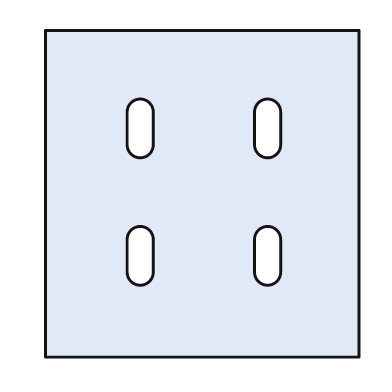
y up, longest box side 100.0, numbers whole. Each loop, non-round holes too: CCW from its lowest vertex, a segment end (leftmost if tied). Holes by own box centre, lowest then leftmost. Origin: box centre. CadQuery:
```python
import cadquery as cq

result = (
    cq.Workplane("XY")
    .moveTo(-48.0, -50.0)
    .lineTo(48.0, -50.0)
    .lineTo(48.0, 50.0)
    .lineTo(-48.0, 50.0)
    .close()
    .moveTo(-23.0, -24.0)
    .threePointArc((-19.0, -28.0), (-15.0, -24.0))
    .lineTo(-15.0, -14.0)
    .threePointArc((-19.0, -10.0), (-23.0, -14.0))
    .close()
    .moveTo(16.0, -24.0)
    .threePointArc((20.0, -28.0), (24.0, -24.0))
    .lineTo(24.0, -14.0)
    .threePointArc((20.0, -10.0), (16.0, -14.0))
    .close()
    .moveTo(-23.0, 15.0)
    .threePointArc((-19.0, 11.0), (-15.0, 15.0))
    .lineTo(-15.0, 25.0)
    .threePointArc((-19.0, 29.0), (-23.0, 25.0))
    .close()
    .moveTo(16.0, 15.0)
    .threePointArc((20.0, 11.0), (24.0, 15.0))
    .lineTo(24.0, 25.0)
    .threePointArc((20.0, 29.0), (16.0, 25.0))
    .close()
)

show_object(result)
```